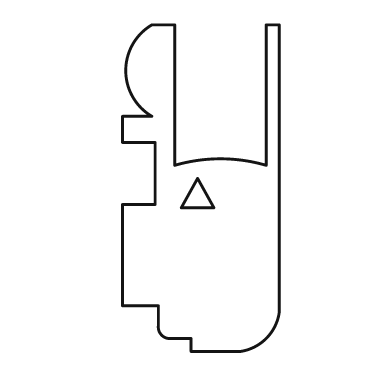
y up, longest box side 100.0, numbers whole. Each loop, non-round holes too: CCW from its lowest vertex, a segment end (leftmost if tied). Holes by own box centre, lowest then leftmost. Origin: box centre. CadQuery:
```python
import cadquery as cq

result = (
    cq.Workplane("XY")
    .moveTo(-3.0, -50.0)
    .lineTo(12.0, -50.0)
    .threePointArc((20.0, -46.0), (24.0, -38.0))
    .lineTo(24.0, 50.0)
    .lineTo(20.0, 50.0)
    .lineTo(20.0, 7.0)
    .threePointArc((6.0, 9.0), (-8.0, 7.0))
    .lineTo(-8.0, 50.0)
    .lineTo(-15.0, 50.0)
    .threePointArc((-23.0, 36.0), (-15.0, 22.0))
    .lineTo(-24.0, 22.0)
    .lineTo(-24.0, 14.0)
    .lineTo(-14.0, 14.0)
    .lineTo(-14.0, -5.0)
    .lineTo(-24.0, -5.0)
    .lineTo(-24.0, -36.0)
    .lineTo(-13.0, -36.0)
    .lineTo(-13.0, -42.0)
    .threePointArc((-12.0, -45.0), (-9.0, -46.0))
    .lineTo(-3.0, -46.0)
    .close()
    .moveTo(-6.0, -6.0)
    .lineTo(4.0, -6.0)
    .lineTo(-1.0, 3.0)
    .close()
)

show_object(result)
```